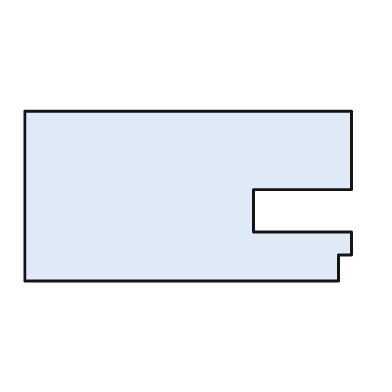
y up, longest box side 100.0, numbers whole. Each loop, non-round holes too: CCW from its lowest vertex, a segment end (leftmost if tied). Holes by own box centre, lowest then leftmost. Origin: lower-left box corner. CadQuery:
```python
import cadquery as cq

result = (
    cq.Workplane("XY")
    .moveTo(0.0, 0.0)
    .lineTo(96.0, 0.0)
    .lineTo(96.0, 8.0)
    .lineTo(100.0, 8.0)
    .lineTo(100.0, 15.0)
    .lineTo(70.0, 15.0)
    .lineTo(70.0, 28.0)
    .lineTo(100.0, 28.0)
    .lineTo(100.0, 52.0)
    .lineTo(0.0, 52.0)
    .close()
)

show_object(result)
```